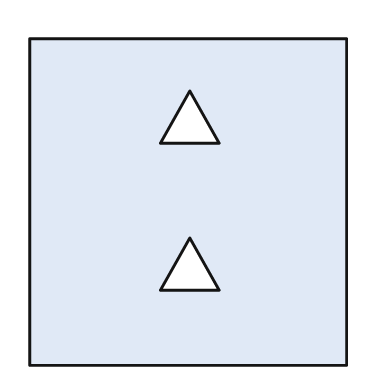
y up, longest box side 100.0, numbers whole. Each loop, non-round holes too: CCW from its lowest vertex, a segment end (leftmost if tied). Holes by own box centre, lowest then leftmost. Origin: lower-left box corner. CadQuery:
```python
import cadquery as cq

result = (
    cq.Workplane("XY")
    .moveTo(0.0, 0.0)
    .lineTo(97.0, 0.0)
    .lineTo(97.0, 100.0)
    .lineTo(0.0, 100.0)
    .close()
    .moveTo(40.0, 23.0)
    .lineTo(58.0, 23.0)
    .lineTo(49.0, 39.0)
    .close()
    .moveTo(40.0, 68.0)
    .lineTo(58.0, 68.0)
    .lineTo(49.0, 84.0)
    .close()
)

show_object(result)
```